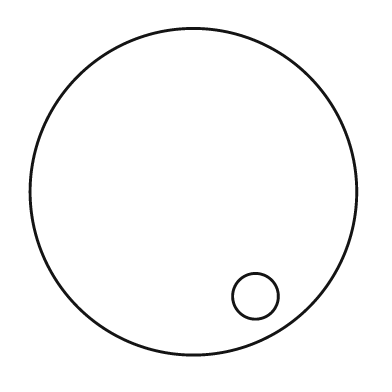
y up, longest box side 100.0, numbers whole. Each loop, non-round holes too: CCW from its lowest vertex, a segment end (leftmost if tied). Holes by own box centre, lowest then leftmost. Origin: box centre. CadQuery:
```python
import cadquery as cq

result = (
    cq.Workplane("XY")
    .moveTo(0.0, 0.0)
    .circle(50.0)
    .moveTo(19.0, -32.0)
    .circle(7.0)
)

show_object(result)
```